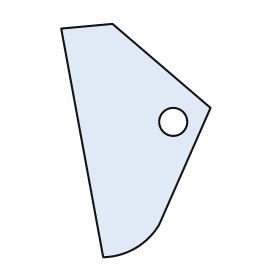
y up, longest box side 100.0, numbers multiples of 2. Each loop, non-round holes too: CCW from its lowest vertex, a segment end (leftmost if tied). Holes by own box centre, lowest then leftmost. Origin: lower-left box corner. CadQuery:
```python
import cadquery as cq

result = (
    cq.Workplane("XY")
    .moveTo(18.0, 0.0)
    .threePointArc((32.0, 4.0), (42.0, 14.0))
    .lineTo(64.0, 64.0)
    .lineTo(22.0, 100.0)
    .lineTo(0.0, 98.0)
    .close()
    .moveTo(48.0, 58.0)
    .circle(6.0)
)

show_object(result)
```